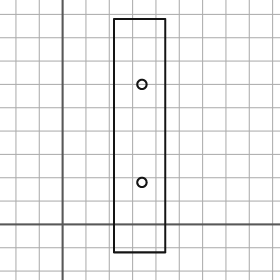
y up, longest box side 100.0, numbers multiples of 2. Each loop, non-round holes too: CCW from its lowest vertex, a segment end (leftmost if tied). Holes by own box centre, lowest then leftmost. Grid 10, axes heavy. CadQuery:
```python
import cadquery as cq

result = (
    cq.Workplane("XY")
    .moveTo(22.0, -12.0)
    .lineTo(44.0, -12.0)
    .lineTo(44.0, 88.0)
    .lineTo(22.0, 88.0)
    .close()
    .moveTo(34.0, 18.0)
    .circle(2.0)
    .moveTo(34.0, 60.0)
    .circle(2.0)
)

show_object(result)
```